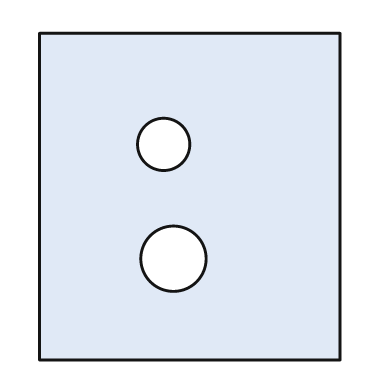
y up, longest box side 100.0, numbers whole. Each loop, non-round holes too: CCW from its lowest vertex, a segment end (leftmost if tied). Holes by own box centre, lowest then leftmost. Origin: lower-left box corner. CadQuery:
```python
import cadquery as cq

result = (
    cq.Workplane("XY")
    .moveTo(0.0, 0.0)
    .lineTo(92.0, 0.0)
    .lineTo(92.0, 100.0)
    .lineTo(0.0, 100.0)
    .close()
    .moveTo(41.0, 31.0)
    .circle(10.0)
    .moveTo(38.0, 66.0)
    .circle(8.0)
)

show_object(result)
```